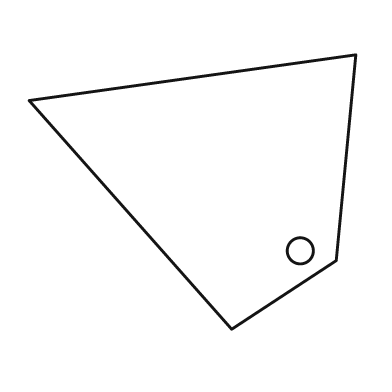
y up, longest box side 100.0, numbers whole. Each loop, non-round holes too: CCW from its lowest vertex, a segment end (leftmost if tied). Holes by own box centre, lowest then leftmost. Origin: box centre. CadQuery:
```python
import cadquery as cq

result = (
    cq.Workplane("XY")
    .moveTo(12.0, -42.0)
    .lineTo(44.0, -21.0)
    .lineTo(50.0, 42.0)
    .lineTo(-50.0, 28.0)
    .close()
    .moveTo(33.0, -18.0)
    .circle(4.0)
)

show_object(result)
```